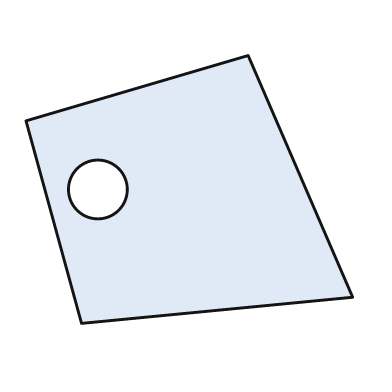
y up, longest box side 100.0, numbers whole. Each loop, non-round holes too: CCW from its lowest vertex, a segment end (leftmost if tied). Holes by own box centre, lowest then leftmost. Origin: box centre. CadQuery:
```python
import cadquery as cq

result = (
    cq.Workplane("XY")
    .moveTo(-33.0, -41.0)
    .lineTo(50.0, -33.0)
    .lineTo(18.0, 41.0)
    .lineTo(-50.0, 21.0)
    .close()
    .moveTo(-28.0, 0.0)
    .circle(9.0)
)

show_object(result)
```